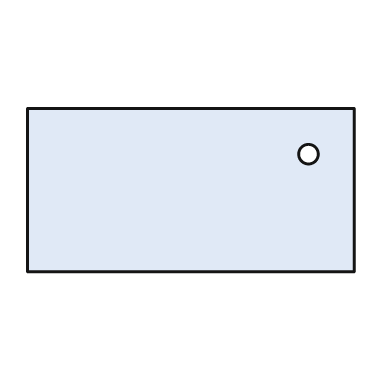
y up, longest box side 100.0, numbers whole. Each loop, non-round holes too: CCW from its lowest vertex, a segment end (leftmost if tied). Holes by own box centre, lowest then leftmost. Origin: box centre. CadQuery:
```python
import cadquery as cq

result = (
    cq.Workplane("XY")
    .moveTo(-50.0, -25.0)
    .lineTo(50.0, -25.0)
    .lineTo(50.0, 25.0)
    .lineTo(-50.0, 25.0)
    .close()
    .moveTo(36.0, 11.0)
    .circle(3.0)
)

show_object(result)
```